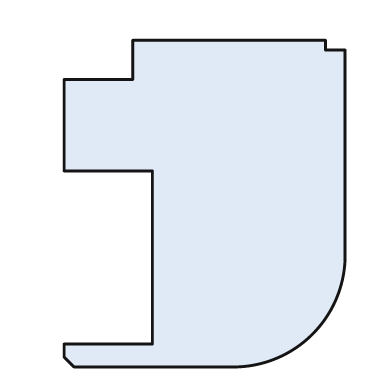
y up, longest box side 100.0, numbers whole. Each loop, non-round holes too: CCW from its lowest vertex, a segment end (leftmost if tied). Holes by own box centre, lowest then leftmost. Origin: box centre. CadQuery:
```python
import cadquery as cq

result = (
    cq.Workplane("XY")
    .moveTo(-40.0, -50.0)
    .lineTo(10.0, -50.0)
    .threePointArc((33.0, -40.0), (43.0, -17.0))
    .lineTo(43.0, 47.0)
    .lineTo(37.0, 47.0)
    .lineTo(37.0, 50.0)
    .lineTo(-22.0, 50.0)
    .lineTo(-22.0, 38.0)
    .lineTo(-43.0, 38.0)
    .lineTo(-43.0, 10.0)
    .lineTo(-16.0, 10.0)
    .lineTo(-16.0, -43.0)
    .lineTo(-43.0, -43.0)
    .lineTo(-43.0, -47.0)
    .close()
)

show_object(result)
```